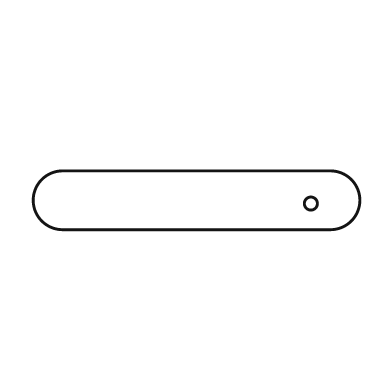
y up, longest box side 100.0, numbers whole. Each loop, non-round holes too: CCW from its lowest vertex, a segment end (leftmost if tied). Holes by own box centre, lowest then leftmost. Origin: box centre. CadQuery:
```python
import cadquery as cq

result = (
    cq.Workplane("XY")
    .moveTo(-41.0, -9.0)
    .lineTo(41.0, -9.0)
    .threePointArc((50.0, 0.0), (41.0, 9.0))
    .lineTo(-41.0, 9.0)
    .threePointArc((-50.0, 0.0), (-41.0, -9.0))
    .close()
    .moveTo(35.0, -1.0)
    .circle(2.0)
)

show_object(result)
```